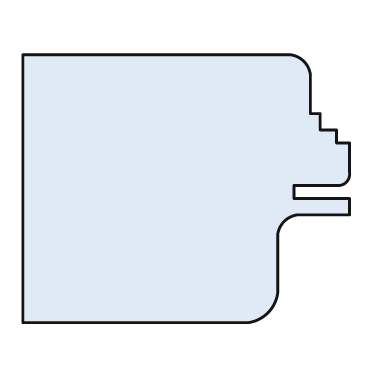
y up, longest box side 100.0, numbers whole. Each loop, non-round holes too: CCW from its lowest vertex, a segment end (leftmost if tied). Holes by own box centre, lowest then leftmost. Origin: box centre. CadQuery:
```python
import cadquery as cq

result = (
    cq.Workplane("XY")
    .moveTo(-50.0, -41.0)
    .lineTo(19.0, -41.0)
    .threePointArc((25.0, -38.0), (28.0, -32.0))
    .lineTo(28.0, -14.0)
    .threePointArc((30.0, -10.0), (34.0, -8.0))
    .lineTo(50.0, -8.0)
    .lineTo(50.0, -3.0)
    .lineTo(33.0, -3.0)
    .lineTo(33.0, 1.0)
    .lineTo(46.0, 1.0)
    .threePointArc((49.0, 2.0), (50.0, 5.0))
    .lineTo(50.0, 14.0)
    .lineTo(46.0, 14.0)
    .lineTo(46.0, 18.0)
    .lineTo(41.0, 18.0)
    .lineTo(41.0, 23.0)
    .lineTo(38.0, 23.0)
    .lineTo(38.0, 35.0)
    .threePointArc((36.0, 39.0), (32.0, 41.0))
    .lineTo(-50.0, 41.0)
    .close()
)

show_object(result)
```